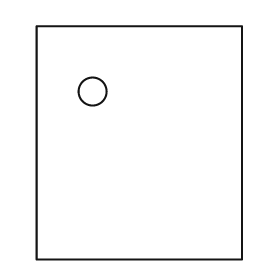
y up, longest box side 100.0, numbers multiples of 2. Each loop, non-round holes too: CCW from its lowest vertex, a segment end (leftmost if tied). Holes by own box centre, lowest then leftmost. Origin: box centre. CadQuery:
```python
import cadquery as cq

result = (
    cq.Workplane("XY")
    .moveTo(-44.0, -50.0)
    .lineTo(44.0, -50.0)
    .lineTo(44.0, 50.0)
    .lineTo(-44.0, 50.0)
    .close()
    .moveTo(-20.0, 22.0)
    .circle(6.0)
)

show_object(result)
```